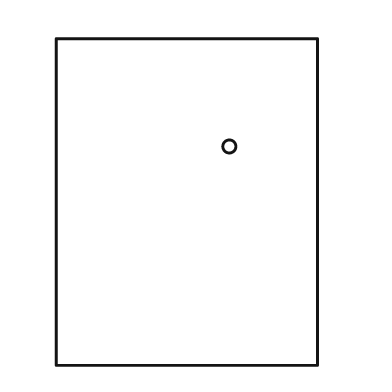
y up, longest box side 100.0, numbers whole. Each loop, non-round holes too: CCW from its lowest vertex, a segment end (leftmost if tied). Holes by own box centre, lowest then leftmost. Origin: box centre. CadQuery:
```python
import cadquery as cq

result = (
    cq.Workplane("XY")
    .moveTo(-40.0, -50.0)
    .lineTo(40.0, -50.0)
    .lineTo(40.0, 50.0)
    .lineTo(-40.0, 50.0)
    .close()
    .moveTo(13.0, 17.0)
    .circle(2.0)
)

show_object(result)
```